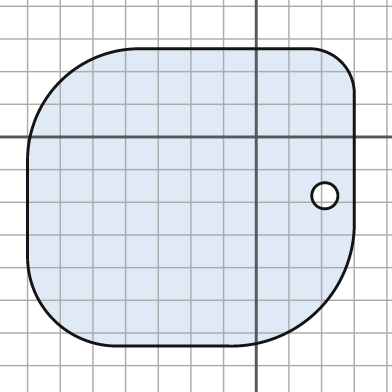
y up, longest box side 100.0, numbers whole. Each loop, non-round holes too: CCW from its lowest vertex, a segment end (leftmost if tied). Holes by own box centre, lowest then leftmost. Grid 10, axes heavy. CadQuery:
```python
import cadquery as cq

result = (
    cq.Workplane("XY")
    .moveTo(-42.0, -64.0)
    .lineTo(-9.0, -64.0)
    .threePointArc((19.0, -53.0), (30.0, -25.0))
    .lineTo(30.0, 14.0)
    .threePointArc((26.0, 23.0), (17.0, 27.0))
    .lineTo(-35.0, 27.0)
    .threePointArc((-60.0, 17.0), (-70.0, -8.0))
    .lineTo(-70.0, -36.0)
    .threePointArc((-62.0, -56.0), (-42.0, -64.0))
    .close()
    .moveTo(21.0, -18.0)
    .circle(4.0)
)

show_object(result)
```